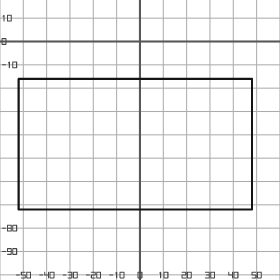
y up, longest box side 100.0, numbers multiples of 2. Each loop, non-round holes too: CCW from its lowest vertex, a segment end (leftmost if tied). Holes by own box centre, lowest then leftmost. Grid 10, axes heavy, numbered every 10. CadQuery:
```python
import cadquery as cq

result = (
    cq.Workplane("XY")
    .moveTo(-52.0, -72.0)
    .lineTo(48.0, -72.0)
    .lineTo(48.0, -16.0)
    .lineTo(-52.0, -16.0)
    .close()
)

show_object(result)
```